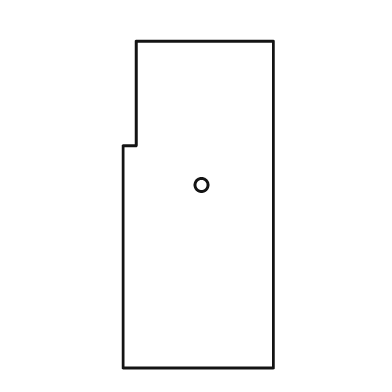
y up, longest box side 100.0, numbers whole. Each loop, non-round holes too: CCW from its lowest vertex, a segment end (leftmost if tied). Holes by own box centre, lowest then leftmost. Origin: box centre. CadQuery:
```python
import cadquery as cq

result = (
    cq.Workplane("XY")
    .moveTo(-23.0, -50.0)
    .lineTo(23.0, -50.0)
    .lineTo(23.0, 50.0)
    .lineTo(-19.0, 50.0)
    .lineTo(-19.0, 18.0)
    .lineTo(-23.0, 18.0)
    .close()
    .moveTo(1.0, 6.0)
    .circle(2.0)
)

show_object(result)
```